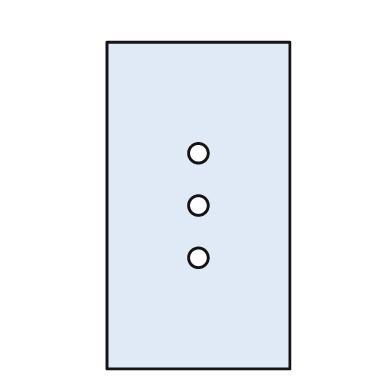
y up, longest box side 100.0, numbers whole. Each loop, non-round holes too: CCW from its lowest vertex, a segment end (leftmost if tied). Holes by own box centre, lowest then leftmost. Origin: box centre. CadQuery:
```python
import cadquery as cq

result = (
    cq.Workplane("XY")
    .moveTo(-28.0, -50.0)
    .lineTo(28.0, -50.0)
    .lineTo(28.0, 50.0)
    .lineTo(-28.0, 50.0)
    .close()
    .moveTo(0.0, -16.0)
    .circle(3.0)
    .moveTo(0.0, 0.0)
    .circle(3.0)
    .moveTo(0.0, 16.0)
    .circle(3.0)
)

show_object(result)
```